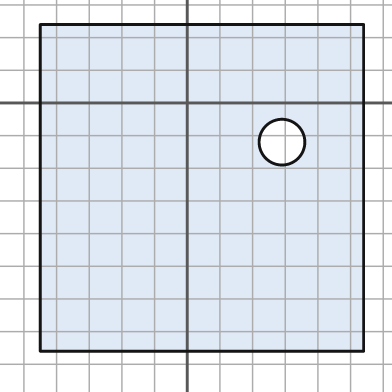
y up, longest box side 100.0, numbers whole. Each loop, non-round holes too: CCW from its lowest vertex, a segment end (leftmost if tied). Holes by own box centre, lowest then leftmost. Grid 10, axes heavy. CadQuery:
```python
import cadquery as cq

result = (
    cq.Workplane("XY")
    .moveTo(-45.0, -76.0)
    .lineTo(54.0, -76.0)
    .lineTo(54.0, 24.0)
    .lineTo(-45.0, 24.0)
    .close()
    .moveTo(29.0, -12.0)
    .circle(7.0)
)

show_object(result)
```